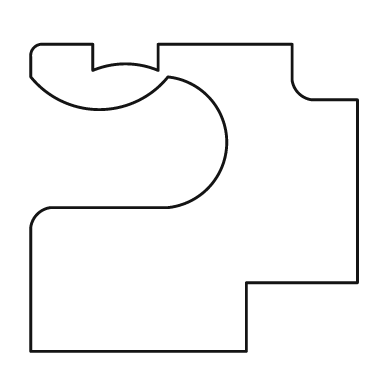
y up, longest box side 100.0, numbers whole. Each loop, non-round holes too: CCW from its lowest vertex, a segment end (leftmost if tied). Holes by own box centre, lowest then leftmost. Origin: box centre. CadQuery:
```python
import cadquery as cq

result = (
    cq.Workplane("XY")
    .moveTo(-50.0, -47.0)
    .lineTo(16.0, -47.0)
    .lineTo(16.0, -26.0)
    .lineTo(50.0, -26.0)
    .lineTo(50.0, 30.0)
    .lineTo(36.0, 30.0)
    .threePointArc((32.0, 32.0), (30.0, 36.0))
    .lineTo(30.0, 47.0)
    .lineTo(-11.0, 47.0)
    .lineTo(-11.0, 39.0)
    .threePointArc((-21.0, 41.0), (-31.0, 39.0))
    .lineTo(-31.0, 47.0)
    .lineTo(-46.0, 47.0)
    .threePointArc((-49.0, 46.0), (-50.0, 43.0))
    .lineTo(-50.0, 37.0)
    .threePointArc((-29.0, 27.0), (-8.0, 37.0))
    .threePointArc((10.0, 17.0), (-8.0, -3.0))
    .lineTo(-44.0, -3.0)
    .threePointArc((-48.0, -5.0), (-50.0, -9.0))
    .close()
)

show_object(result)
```